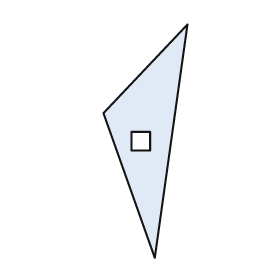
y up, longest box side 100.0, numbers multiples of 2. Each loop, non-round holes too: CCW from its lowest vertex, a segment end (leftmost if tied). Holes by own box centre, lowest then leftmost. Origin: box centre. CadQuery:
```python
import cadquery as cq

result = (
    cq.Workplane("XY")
    .moveTo(4.0, -50.0)
    .lineTo(18.0, 50.0)
    .lineTo(-18.0, 12.0)
    .close()
    .moveTo(-6.0, -4.0)
    .lineTo(2.0, -4.0)
    .lineTo(2.0, 4.0)
    .lineTo(-6.0, 4.0)
    .close()
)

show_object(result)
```